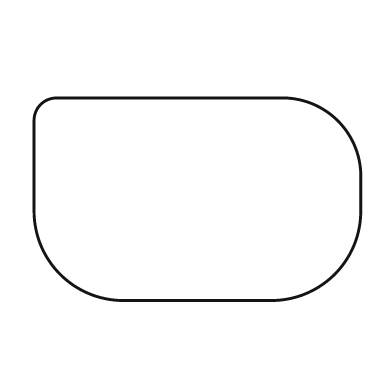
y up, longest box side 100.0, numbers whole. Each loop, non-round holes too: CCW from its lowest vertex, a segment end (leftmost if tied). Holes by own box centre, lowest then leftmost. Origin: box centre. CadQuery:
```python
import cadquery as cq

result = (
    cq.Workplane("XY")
    .moveTo(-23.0, -31.0)
    .lineTo(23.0, -31.0)
    .threePointArc((42.0, -23.0), (50.0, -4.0))
    .lineTo(50.0, 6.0)
    .threePointArc((43.0, 24.0), (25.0, 31.0))
    .lineTo(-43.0, 31.0)
    .threePointArc((-48.0, 29.0), (-50.0, 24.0))
    .lineTo(-50.0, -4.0)
    .threePointArc((-42.0, -23.0), (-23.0, -31.0))
    .close()
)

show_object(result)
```